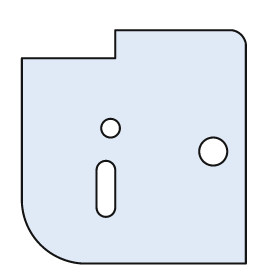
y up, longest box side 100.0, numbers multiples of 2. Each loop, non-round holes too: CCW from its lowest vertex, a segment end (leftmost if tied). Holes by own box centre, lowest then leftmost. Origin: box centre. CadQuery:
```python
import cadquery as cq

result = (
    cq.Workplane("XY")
    .moveTo(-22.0, -50.0)
    .lineTo(48.0, -50.0)
    .lineTo(48.0, 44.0)
    .threePointArc((46.0, 48.0), (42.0, 50.0))
    .lineTo(-8.0, 50.0)
    .lineTo(-8.0, 38.0)
    .lineTo(-48.0, 38.0)
    .lineTo(-48.0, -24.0)
    .threePointArc((-40.0, -42.0), (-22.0, -50.0))
    .close()
    .moveTo(-16.0, -26.0)
    .threePointArc((-12.0, -30.0), (-8.0, -26.0))
    .lineTo(-8.0, -10.0)
    .threePointArc((-12.0, -6.0), (-16.0, -10.0))
    .close()
    .moveTo(34.0, -2.0)
    .circle(6.0)
    .moveTo(-10.0, 8.0)
    .circle(4.0)
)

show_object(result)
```